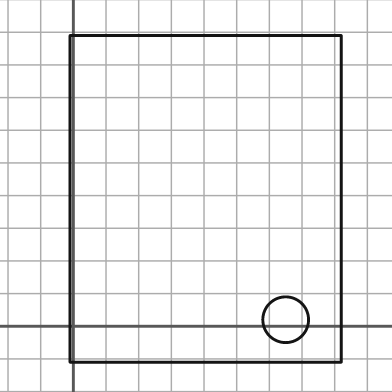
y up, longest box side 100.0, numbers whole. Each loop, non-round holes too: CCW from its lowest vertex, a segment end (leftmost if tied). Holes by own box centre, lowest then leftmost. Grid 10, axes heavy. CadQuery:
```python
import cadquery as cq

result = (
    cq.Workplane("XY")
    .moveTo(-1.0, -11.0)
    .lineTo(82.0, -11.0)
    .lineTo(82.0, 89.0)
    .lineTo(-1.0, 89.0)
    .close()
    .moveTo(65.0, 2.0)
    .circle(7.0)
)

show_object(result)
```